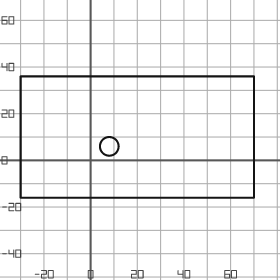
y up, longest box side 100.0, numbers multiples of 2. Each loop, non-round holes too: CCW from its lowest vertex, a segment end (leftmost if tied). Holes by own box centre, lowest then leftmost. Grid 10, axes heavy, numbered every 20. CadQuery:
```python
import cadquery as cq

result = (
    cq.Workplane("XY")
    .moveTo(-30.0, -16.0)
    .lineTo(70.0, -16.0)
    .lineTo(70.0, 36.0)
    .lineTo(-30.0, 36.0)
    .close()
    .moveTo(8.0, 6.0)
    .circle(4.0)
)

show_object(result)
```